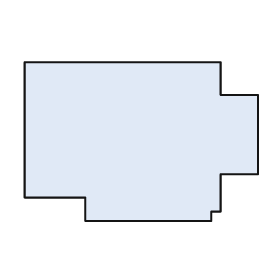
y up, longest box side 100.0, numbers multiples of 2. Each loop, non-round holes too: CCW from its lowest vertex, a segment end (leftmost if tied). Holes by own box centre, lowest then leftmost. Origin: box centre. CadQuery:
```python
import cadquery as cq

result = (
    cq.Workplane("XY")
    .moveTo(-24.0, -34.0)
    .lineTo(30.0, -34.0)
    .lineTo(30.0, -30.0)
    .lineTo(34.0, -30.0)
    .lineTo(34.0, -14.0)
    .lineTo(50.0, -14.0)
    .lineTo(50.0, 20.0)
    .lineTo(34.0, 20.0)
    .lineTo(34.0, 34.0)
    .lineTo(-50.0, 34.0)
    .lineTo(-50.0, -24.0)
    .lineTo(-24.0, -24.0)
    .close()
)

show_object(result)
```